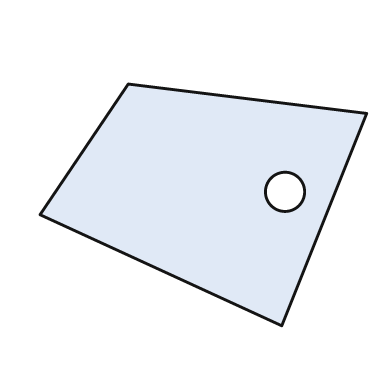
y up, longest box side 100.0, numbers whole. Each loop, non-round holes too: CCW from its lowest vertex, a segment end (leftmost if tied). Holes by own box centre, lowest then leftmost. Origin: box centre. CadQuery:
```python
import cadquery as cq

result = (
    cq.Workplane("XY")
    .moveTo(24.0, -37.0)
    .lineTo(50.0, 28.0)
    .lineTo(-23.0, 37.0)
    .lineTo(-50.0, -3.0)
    .close()
    .moveTo(25.0, 4.0)
    .circle(6.0)
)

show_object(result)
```